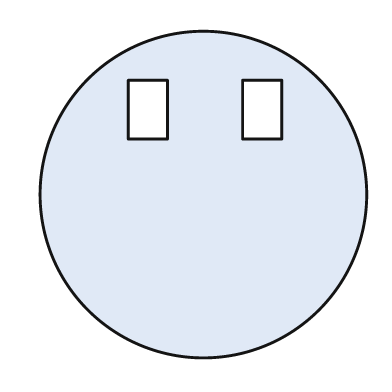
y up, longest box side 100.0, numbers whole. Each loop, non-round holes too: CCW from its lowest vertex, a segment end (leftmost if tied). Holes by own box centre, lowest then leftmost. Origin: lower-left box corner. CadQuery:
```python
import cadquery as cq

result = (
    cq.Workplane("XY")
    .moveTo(50.0, 50.0)
    .circle(50.0)
    .moveTo(27.0, 67.0)
    .lineTo(39.0, 67.0)
    .lineTo(39.0, 85.0)
    .lineTo(27.0, 85.0)
    .close()
    .moveTo(62.0, 67.0)
    .lineTo(74.0, 67.0)
    .lineTo(74.0, 85.0)
    .lineTo(62.0, 85.0)
    .close()
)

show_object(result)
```